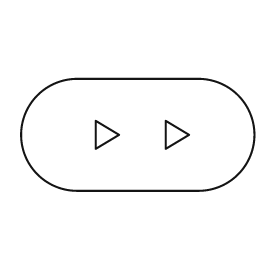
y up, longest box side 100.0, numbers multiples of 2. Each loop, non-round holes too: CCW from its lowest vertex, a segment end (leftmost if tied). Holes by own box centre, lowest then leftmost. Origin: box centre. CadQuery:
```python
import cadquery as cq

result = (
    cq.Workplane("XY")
    .moveTo(-26.0, -24.0)
    .lineTo(26.0, -24.0)
    .threePointArc((50.0, 0.0), (26.0, 24.0))
    .lineTo(-26.0, 24.0)
    .threePointArc((-50.0, 0.0), (-26.0, -24.0))
    .close()
    .moveTo(-18.0, -6.0)
    .lineTo(-8.0, 0.0)
    .lineTo(-18.0, 6.0)
    .close()
    .moveTo(12.0, -6.0)
    .lineTo(22.0, 0.0)
    .lineTo(12.0, 6.0)
    .close()
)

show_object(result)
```